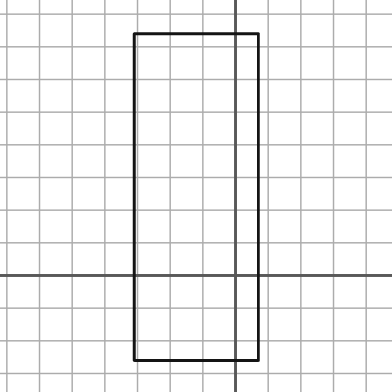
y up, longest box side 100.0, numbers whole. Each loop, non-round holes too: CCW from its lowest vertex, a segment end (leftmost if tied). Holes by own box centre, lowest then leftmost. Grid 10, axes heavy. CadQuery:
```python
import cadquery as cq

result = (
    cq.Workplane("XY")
    .moveTo(-31.0, -26.0)
    .lineTo(7.0, -26.0)
    .lineTo(7.0, 74.0)
    .lineTo(-31.0, 74.0)
    .close()
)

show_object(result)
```